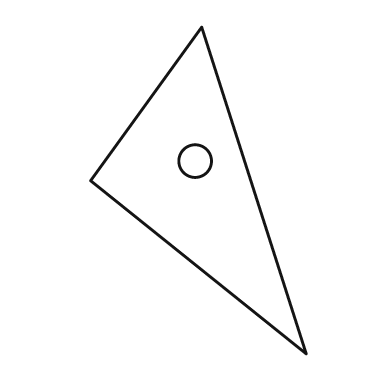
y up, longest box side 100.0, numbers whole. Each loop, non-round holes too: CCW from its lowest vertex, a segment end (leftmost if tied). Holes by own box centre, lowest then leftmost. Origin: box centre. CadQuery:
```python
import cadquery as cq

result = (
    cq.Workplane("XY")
    .moveTo(33.0, -50.0)
    .lineTo(1.0, 50.0)
    .lineTo(-33.0, 3.0)
    .close()
    .moveTo(-1.0, 9.0)
    .circle(5.0)
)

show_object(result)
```